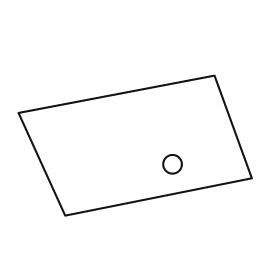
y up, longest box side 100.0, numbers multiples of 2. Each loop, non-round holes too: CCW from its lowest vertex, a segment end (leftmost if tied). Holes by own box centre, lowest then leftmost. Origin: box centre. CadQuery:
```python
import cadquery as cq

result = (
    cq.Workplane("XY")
    .moveTo(-30.0, -30.0)
    .lineTo(50.0, -14.0)
    .lineTo(34.0, 30.0)
    .lineTo(-50.0, 14.0)
    .close()
    .moveTo(16.0, -8.0)
    .circle(4.0)
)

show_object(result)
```